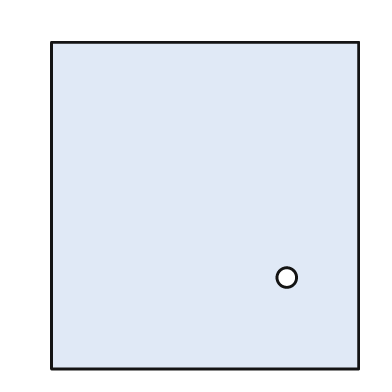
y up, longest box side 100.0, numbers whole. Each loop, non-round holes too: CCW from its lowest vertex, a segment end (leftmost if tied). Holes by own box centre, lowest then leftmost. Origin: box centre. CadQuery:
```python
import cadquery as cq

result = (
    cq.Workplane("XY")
    .moveTo(-47.0, -50.0)
    .lineTo(47.0, -50.0)
    .lineTo(47.0, 50.0)
    .lineTo(-47.0, 50.0)
    .close()
    .moveTo(25.0, -22.0)
    .circle(3.0)
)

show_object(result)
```